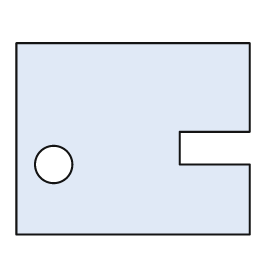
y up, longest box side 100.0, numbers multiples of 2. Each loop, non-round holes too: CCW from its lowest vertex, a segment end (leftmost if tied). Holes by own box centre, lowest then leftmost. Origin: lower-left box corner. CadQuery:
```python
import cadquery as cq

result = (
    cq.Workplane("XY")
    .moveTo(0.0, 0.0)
    .lineTo(100.0, 0.0)
    .lineTo(100.0, 30.0)
    .lineTo(70.0, 30.0)
    .lineTo(70.0, 44.0)
    .lineTo(100.0, 44.0)
    .lineTo(100.0, 82.0)
    .lineTo(0.0, 82.0)
    .close()
    .moveTo(16.0, 30.0)
    .circle(8.0)
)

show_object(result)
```